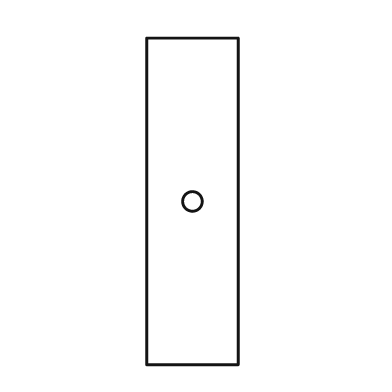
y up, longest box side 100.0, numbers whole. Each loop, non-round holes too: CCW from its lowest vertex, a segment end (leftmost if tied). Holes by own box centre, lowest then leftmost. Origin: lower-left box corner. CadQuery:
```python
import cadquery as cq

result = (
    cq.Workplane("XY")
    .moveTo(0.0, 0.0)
    .lineTo(28.0, 0.0)
    .lineTo(28.0, 100.0)
    .lineTo(0.0, 100.0)
    .close()
    .moveTo(14.0, 50.0)
    .circle(3.0)
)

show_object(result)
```